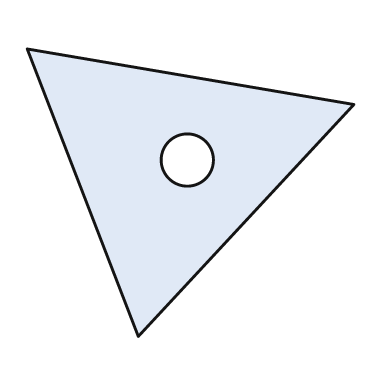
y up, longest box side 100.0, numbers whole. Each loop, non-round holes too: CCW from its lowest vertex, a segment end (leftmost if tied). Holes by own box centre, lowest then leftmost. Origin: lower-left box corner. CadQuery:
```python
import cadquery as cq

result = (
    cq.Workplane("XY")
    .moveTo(34.0, 0.0)
    .lineTo(100.0, 71.0)
    .lineTo(0.0, 88.0)
    .close()
    .moveTo(49.0, 54.0)
    .circle(8.0)
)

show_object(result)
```